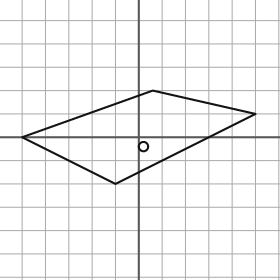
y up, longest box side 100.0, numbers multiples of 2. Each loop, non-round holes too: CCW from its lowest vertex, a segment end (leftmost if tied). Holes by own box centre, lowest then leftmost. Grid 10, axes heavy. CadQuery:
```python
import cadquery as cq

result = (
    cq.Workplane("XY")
    .moveTo(-10.0, -20.0)
    .lineTo(50.0, 10.0)
    .lineTo(6.0, 20.0)
    .lineTo(-50.0, 0.0)
    .close()
    .moveTo(2.0, -4.0)
    .circle(2.0)
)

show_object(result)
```